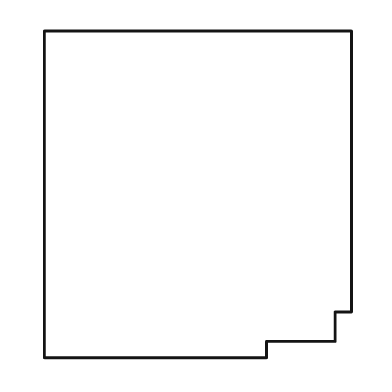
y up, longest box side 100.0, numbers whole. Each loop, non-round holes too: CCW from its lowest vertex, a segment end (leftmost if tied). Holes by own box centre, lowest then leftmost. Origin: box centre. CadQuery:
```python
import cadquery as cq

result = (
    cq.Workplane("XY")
    .moveTo(-47.0, -50.0)
    .lineTo(21.0, -50.0)
    .lineTo(21.0, -45.0)
    .lineTo(42.0, -45.0)
    .lineTo(42.0, -36.0)
    .lineTo(47.0, -36.0)
    .lineTo(47.0, 50.0)
    .lineTo(-47.0, 50.0)
    .close()
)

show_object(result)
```